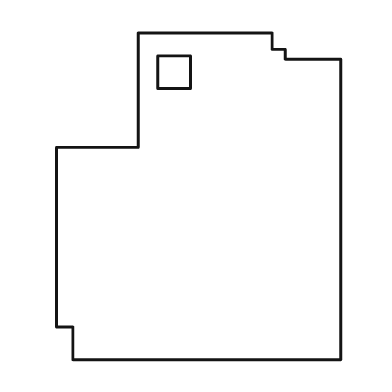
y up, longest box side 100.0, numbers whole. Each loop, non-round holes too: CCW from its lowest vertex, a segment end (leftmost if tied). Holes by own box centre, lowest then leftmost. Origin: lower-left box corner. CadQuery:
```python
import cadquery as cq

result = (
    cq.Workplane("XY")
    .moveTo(5.0, 0.0)
    .lineTo(87.0, 0.0)
    .lineTo(87.0, 92.0)
    .lineTo(70.0, 92.0)
    .lineTo(70.0, 95.0)
    .lineTo(66.0, 95.0)
    .lineTo(66.0, 100.0)
    .lineTo(25.0, 100.0)
    .lineTo(25.0, 65.0)
    .lineTo(0.0, 65.0)
    .lineTo(0.0, 10.0)
    .lineTo(5.0, 10.0)
    .close()
    .moveTo(31.0, 83.0)
    .lineTo(41.0, 83.0)
    .lineTo(41.0, 93.0)
    .lineTo(31.0, 93.0)
    .close()
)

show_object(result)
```